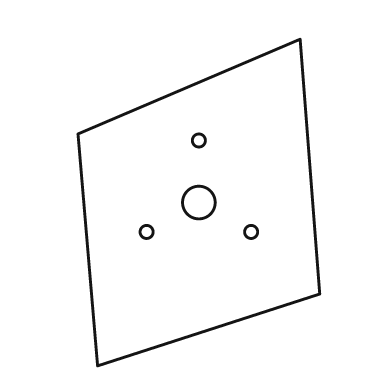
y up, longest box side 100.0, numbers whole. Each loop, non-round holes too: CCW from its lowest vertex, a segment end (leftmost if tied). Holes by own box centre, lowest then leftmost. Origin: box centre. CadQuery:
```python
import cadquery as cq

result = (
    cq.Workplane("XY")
    .moveTo(-31.0, -50.0)
    .lineTo(37.0, -28.0)
    .lineTo(31.0, 50.0)
    .lineTo(-37.0, 21.0)
    .close()
    .moveTo(-16.0, -9.0)
    .circle(2.0)
    .moveTo(16.0, -9.0)
    .circle(2.0)
    .moveTo(0.0, 0.0)
    .circle(5.0)
    .moveTo(0.0, 19.0)
    .circle(2.0)
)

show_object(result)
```